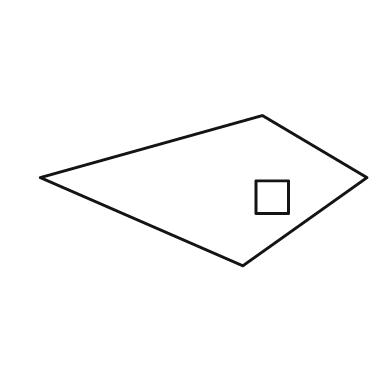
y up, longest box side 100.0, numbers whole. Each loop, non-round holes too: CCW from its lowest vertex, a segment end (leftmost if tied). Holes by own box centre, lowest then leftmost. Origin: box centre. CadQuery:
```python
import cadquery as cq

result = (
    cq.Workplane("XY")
    .moveTo(12.0, -23.0)
    .lineTo(50.0, 4.0)
    .lineTo(18.0, 23.0)
    .lineTo(-50.0, 4.0)
    .close()
    .moveTo(16.0, -7.0)
    .lineTo(26.0, -7.0)
    .lineTo(26.0, 3.0)
    .lineTo(16.0, 3.0)
    .close()
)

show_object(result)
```